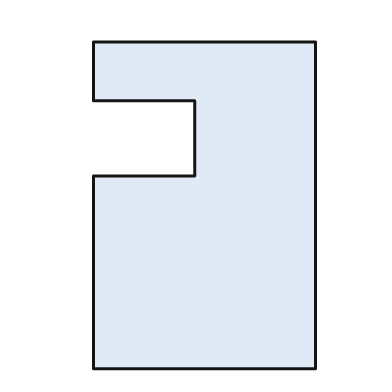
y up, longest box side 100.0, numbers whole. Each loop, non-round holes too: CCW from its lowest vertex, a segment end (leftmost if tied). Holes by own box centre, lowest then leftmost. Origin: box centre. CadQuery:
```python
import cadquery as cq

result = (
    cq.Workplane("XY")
    .moveTo(-34.0, -50.0)
    .lineTo(34.0, -50.0)
    .lineTo(34.0, 50.0)
    .lineTo(-34.0, 50.0)
    .lineTo(-34.0, 32.0)
    .lineTo(-3.0, 32.0)
    .lineTo(-3.0, 9.0)
    .lineTo(-34.0, 9.0)
    .close()
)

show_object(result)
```